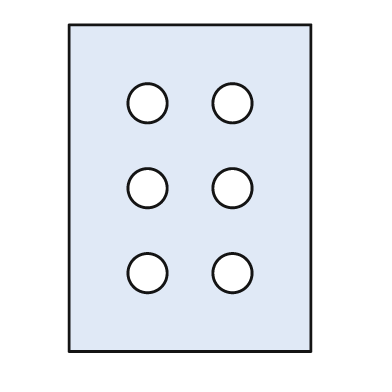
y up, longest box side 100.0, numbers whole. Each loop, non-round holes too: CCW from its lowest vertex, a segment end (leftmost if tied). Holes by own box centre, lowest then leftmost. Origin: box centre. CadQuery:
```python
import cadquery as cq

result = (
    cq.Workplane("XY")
    .moveTo(-37.0, -50.0)
    .lineTo(37.0, -50.0)
    .lineTo(37.0, 50.0)
    .lineTo(-37.0, 50.0)
    .close()
    .moveTo(-13.0, -26.0)
    .circle(6.0)
    .moveTo(13.0, -26.0)
    .circle(6.0)
    .moveTo(-13.0, 0.0)
    .circle(6.0)
    .moveTo(13.0, 0.0)
    .circle(6.0)
    .moveTo(-13.0, 26.0)
    .circle(6.0)
    .moveTo(13.0, 26.0)
    .circle(6.0)
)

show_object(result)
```